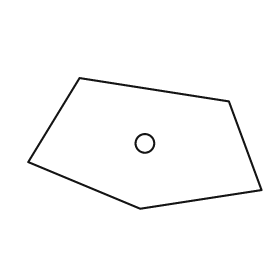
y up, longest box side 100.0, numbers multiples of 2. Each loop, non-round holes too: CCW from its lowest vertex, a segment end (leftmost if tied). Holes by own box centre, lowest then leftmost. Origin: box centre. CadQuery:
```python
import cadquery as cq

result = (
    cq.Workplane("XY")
    .moveTo(-2.0, -28.0)
    .lineTo(50.0, -20.0)
    .lineTo(36.0, 18.0)
    .lineTo(-28.0, 28.0)
    .lineTo(-50.0, -8.0)
    .close()
    .moveTo(0.0, 0.0)
    .circle(4.0)
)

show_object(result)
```